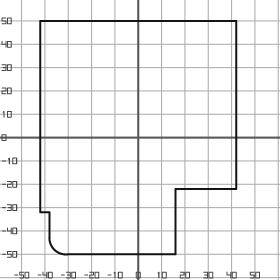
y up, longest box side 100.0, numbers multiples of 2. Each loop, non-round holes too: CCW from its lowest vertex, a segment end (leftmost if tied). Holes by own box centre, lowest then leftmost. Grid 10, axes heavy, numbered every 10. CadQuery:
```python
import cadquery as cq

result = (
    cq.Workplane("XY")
    .moveTo(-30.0, -50.0)
    .lineTo(16.0, -50.0)
    .lineTo(16.0, -22.0)
    .lineTo(42.0, -22.0)
    .lineTo(42.0, 50.0)
    .lineTo(-42.0, 50.0)
    .lineTo(-42.0, -32.0)
    .lineTo(-38.0, -32.0)
    .lineTo(-38.0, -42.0)
    .threePointArc((-36.0, -48.0), (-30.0, -50.0))
    .close()
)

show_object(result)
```